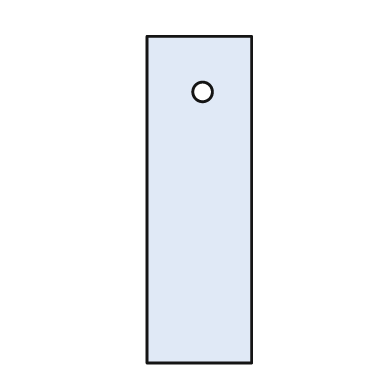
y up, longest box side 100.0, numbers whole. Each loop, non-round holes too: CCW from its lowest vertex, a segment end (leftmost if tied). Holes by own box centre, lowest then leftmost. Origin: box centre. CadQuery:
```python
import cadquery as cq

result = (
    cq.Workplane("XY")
    .moveTo(-16.0, -50.0)
    .lineTo(16.0, -50.0)
    .lineTo(16.0, 50.0)
    .lineTo(-16.0, 50.0)
    .close()
    .moveTo(1.0, 33.0)
    .circle(3.0)
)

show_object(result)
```